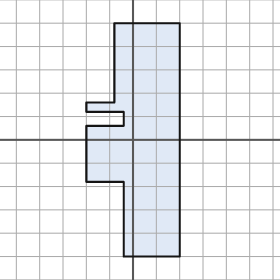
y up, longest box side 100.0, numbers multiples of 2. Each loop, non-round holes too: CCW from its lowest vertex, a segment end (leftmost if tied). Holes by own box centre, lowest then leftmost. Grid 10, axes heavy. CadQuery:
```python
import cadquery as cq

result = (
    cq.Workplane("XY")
    .moveTo(-4.0, -50.0)
    .lineTo(20.0, -50.0)
    .lineTo(20.0, 50.0)
    .lineTo(-8.0, 50.0)
    .lineTo(-8.0, 16.0)
    .lineTo(-20.0, 16.0)
    .lineTo(-20.0, 12.0)
    .lineTo(-4.0, 12.0)
    .lineTo(-4.0, 6.0)
    .lineTo(-20.0, 6.0)
    .lineTo(-20.0, -18.0)
    .lineTo(-4.0, -18.0)
    .close()
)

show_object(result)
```